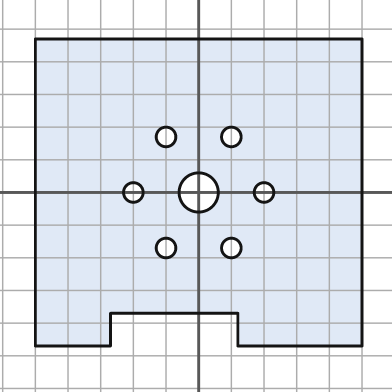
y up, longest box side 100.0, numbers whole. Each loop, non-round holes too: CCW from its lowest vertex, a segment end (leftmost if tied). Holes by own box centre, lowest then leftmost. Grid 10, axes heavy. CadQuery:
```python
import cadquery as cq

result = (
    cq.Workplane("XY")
    .moveTo(-50.0, -47.0)
    .lineTo(-27.0, -47.0)
    .lineTo(-27.0, -37.0)
    .lineTo(12.0, -37.0)
    .lineTo(12.0, -47.0)
    .lineTo(50.0, -47.0)
    .lineTo(50.0, 47.0)
    .lineTo(-50.0, 47.0)
    .close()
    .moveTo(-10.0, -17.0)
    .circle(3.0)
    .moveTo(10.0, -17.0)
    .circle(3.0)
    .moveTo(-20.0, 0.0)
    .circle(3.0)
    .moveTo(0.0, 0.0)
    .circle(6.0)
    .moveTo(20.0, 0.0)
    .circle(3.0)
    .moveTo(-10.0, 17.0)
    .circle(3.0)
    .moveTo(10.0, 17.0)
    .circle(3.0)
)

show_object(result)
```